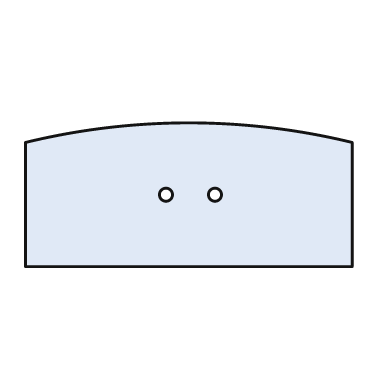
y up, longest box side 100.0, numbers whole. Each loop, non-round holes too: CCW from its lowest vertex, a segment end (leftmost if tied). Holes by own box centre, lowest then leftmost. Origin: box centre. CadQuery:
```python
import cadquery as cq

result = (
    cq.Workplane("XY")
    .moveTo(-50.0, -22.0)
    .lineTo(50.0, -22.0)
    .lineTo(50.0, 16.0)
    .threePointArc((0.0, 22.0), (-50.0, 16.0))
    .close()
    .moveTo(-7.0, 0.0)
    .circle(2.0)
    .moveTo(8.0, 0.0)
    .circle(2.0)
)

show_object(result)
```